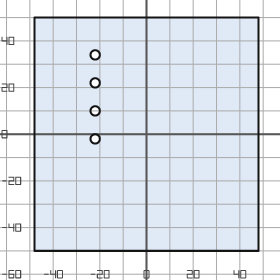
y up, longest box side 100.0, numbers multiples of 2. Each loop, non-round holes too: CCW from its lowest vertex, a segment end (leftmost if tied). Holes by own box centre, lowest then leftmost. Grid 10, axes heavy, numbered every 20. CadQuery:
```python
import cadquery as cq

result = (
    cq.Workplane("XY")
    .moveTo(-48.0, -50.0)
    .lineTo(48.0, -50.0)
    .lineTo(48.0, 50.0)
    .lineTo(-48.0, 50.0)
    .close()
    .moveTo(-22.0, -2.0)
    .circle(2.0)
    .moveTo(-22.0, 10.0)
    .circle(2.0)
    .moveTo(-22.0, 22.0)
    .circle(2.0)
    .moveTo(-22.0, 34.0)
    .circle(2.0)
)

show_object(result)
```